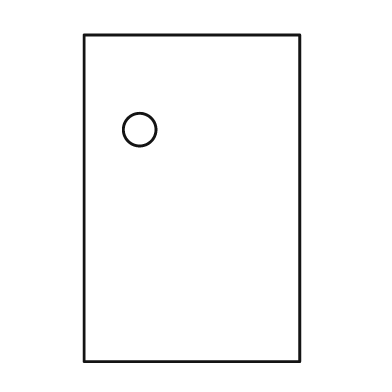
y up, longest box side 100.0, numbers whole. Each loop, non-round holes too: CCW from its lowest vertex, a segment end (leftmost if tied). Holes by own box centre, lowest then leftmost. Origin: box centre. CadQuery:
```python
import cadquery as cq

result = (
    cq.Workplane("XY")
    .moveTo(-33.0, -50.0)
    .lineTo(33.0, -50.0)
    .lineTo(33.0, 50.0)
    .lineTo(-33.0, 50.0)
    .close()
    .moveTo(-16.0, 21.0)
    .circle(5.0)
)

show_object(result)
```